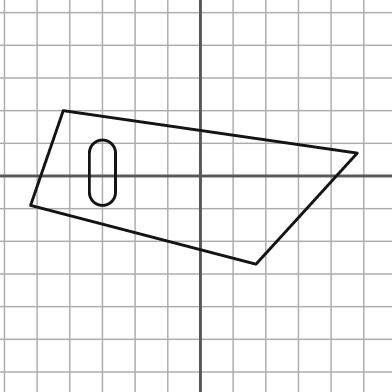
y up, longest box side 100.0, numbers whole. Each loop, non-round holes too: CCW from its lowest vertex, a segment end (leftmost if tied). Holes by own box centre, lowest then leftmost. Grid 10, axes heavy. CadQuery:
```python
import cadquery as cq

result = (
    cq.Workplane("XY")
    .moveTo(17.0, -27.0)
    .lineTo(48.0, 7.0)
    .lineTo(-42.0, 20.0)
    .lineTo(-52.0, -9.0)
    .close()
    .moveTo(-34.0, -5.0)
    .threePointArc((-30.0, -9.0), (-26.0, -5.0))
    .lineTo(-26.0, 7.0)
    .threePointArc((-30.0, 11.0), (-34.0, 7.0))
    .close()
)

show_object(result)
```